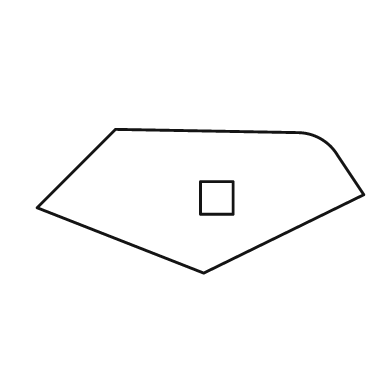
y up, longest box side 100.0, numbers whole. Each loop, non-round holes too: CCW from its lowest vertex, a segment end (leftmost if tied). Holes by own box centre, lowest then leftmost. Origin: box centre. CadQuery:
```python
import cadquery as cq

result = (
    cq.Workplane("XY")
    .moveTo(1.0, -22.0)
    .lineTo(50.0, 2.0)
    .lineTo(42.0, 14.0)
    .threePointArc((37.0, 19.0), (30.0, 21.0))
    .lineTo(-26.0, 22.0)
    .lineTo(-50.0, -2.0)
    .close()
    .moveTo(0.0, -4.0)
    .lineTo(10.0, -4.0)
    .lineTo(10.0, 6.0)
    .lineTo(0.0, 6.0)
    .close()
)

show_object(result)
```